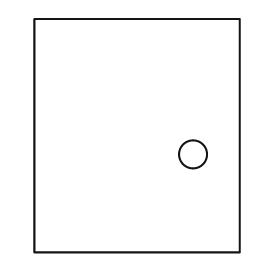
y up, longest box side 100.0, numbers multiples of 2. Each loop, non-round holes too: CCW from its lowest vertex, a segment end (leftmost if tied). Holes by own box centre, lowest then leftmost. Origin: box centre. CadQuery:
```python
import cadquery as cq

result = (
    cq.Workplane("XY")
    .moveTo(-44.0, -50.0)
    .lineTo(44.0, -50.0)
    .lineTo(44.0, 50.0)
    .lineTo(-44.0, 50.0)
    .close()
    .moveTo(24.0, -8.0)
    .circle(6.0)
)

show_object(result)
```